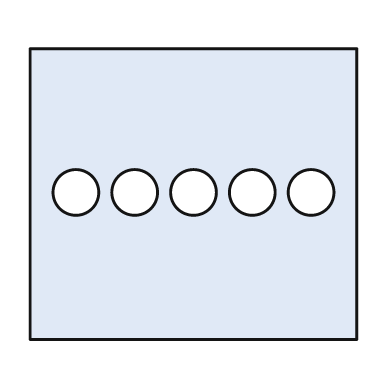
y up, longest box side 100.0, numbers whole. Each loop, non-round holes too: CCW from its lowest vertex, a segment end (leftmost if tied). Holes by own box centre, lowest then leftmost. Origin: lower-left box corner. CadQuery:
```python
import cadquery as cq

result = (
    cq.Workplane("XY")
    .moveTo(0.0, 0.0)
    .lineTo(100.0, 0.0)
    .lineTo(100.0, 89.0)
    .lineTo(0.0, 89.0)
    .close()
    .moveTo(14.0, 45.0)
    .circle(7.0)
    .moveTo(32.0, 45.0)
    .circle(7.0)
    .moveTo(50.0, 45.0)
    .circle(7.0)
    .moveTo(68.0, 45.0)
    .circle(7.0)
    .moveTo(86.0, 45.0)
    .circle(7.0)
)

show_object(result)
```